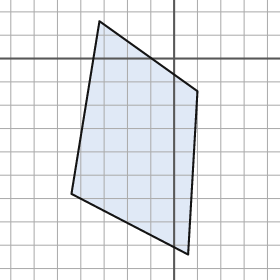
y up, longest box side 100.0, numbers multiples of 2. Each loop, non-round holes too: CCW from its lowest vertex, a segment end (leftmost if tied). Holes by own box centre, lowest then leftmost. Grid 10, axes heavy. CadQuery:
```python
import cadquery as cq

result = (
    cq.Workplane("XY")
    .moveTo(6.0, -84.0)
    .lineTo(10.0, -14.0)
    .lineTo(-32.0, 16.0)
    .lineTo(-44.0, -58.0)
    .close()
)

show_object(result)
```